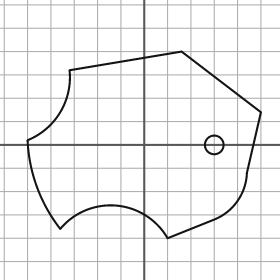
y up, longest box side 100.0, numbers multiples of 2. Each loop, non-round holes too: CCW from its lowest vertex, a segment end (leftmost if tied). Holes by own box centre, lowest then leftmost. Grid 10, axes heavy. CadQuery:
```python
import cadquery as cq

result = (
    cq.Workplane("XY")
    .moveTo(10.0, -40.0)
    .lineTo(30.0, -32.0)
    .threePointArc((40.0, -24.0), (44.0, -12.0))
    .lineTo(50.0, 14.0)
    .lineTo(16.0, 40.0)
    .lineTo(-32.0, 32.0)
    .threePointArc((-36.0, 14.0), (-50.0, 2.0))
    .threePointArc((-46.0, -18.0), (-36.0, -36.0))
    .threePointArc((-12.0, -26.0), (10.0, -40.0))
    .close()
    .moveTo(30.0, 0.0)
    .circle(4.0)
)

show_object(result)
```